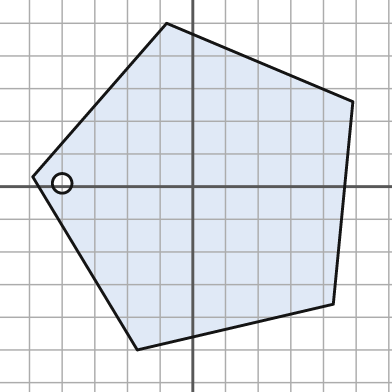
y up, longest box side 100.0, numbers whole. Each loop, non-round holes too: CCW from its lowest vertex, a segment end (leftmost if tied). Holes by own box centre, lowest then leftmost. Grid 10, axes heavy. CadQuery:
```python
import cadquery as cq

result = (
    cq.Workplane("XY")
    .moveTo(-17.0, -50.0)
    .lineTo(43.0, -36.0)
    .lineTo(49.0, 26.0)
    .lineTo(-8.0, 50.0)
    .lineTo(-49.0, 3.0)
    .close()
    .moveTo(-40.0, 1.0)
    .circle(3.0)
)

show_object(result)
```